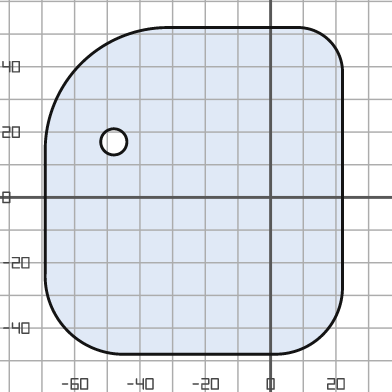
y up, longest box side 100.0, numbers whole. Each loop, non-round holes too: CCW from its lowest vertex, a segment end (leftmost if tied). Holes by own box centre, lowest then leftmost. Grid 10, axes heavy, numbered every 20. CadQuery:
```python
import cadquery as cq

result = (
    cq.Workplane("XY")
    .moveTo(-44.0, -48.0)
    .lineTo(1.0, -48.0)
    .threePointArc((16.0, -42.0), (22.0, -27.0))
    .lineTo(22.0, 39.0)
    .threePointArc((18.0, 48.0), (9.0, 52.0))
    .lineTo(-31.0, 52.0)
    .threePointArc((-58.0, 41.0), (-69.0, 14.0))
    .lineTo(-69.0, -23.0)
    .threePointArc((-62.0, -41.0), (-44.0, -48.0))
    .close()
    .moveTo(-48.0, 17.0)
    .circle(4.0)
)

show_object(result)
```